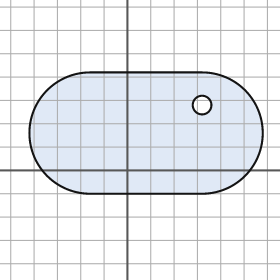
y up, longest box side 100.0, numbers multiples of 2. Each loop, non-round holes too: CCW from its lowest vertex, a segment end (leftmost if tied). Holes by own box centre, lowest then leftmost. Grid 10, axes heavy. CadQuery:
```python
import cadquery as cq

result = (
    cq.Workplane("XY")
    .moveTo(-16.0, -10.0)
    .lineTo(32.0, -10.0)
    .threePointArc((58.0, 16.0), (32.0, 42.0))
    .lineTo(-16.0, 42.0)
    .threePointArc((-42.0, 16.0), (-16.0, -10.0))
    .close()
    .moveTo(32.0, 28.0)
    .circle(4.0)
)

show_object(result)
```